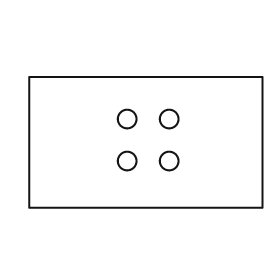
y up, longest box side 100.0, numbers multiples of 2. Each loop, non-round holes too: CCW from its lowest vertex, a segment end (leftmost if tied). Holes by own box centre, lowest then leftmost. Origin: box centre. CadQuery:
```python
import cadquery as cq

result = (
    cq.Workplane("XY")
    .moveTo(-50.0, -28.0)
    .lineTo(50.0, -28.0)
    .lineTo(50.0, 28.0)
    .lineTo(-50.0, 28.0)
    .close()
    .moveTo(-8.0, -8.0)
    .circle(4.0)
    .moveTo(10.0, -8.0)
    .circle(4.0)
    .moveTo(-8.0, 10.0)
    .circle(4.0)
    .moveTo(10.0, 10.0)
    .circle(4.0)
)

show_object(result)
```